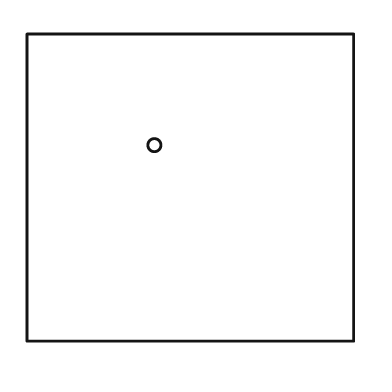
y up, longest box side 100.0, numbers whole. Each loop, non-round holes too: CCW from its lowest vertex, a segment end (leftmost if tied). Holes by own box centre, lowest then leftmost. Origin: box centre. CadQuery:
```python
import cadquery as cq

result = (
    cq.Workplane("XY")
    .moveTo(-50.0, -47.0)
    .lineTo(50.0, -47.0)
    .lineTo(50.0, 47.0)
    .lineTo(-50.0, 47.0)
    .close()
    .moveTo(-11.0, 13.0)
    .circle(2.0)
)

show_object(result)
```